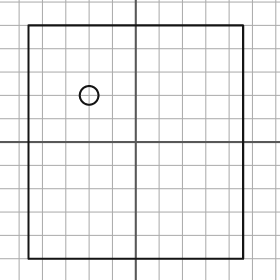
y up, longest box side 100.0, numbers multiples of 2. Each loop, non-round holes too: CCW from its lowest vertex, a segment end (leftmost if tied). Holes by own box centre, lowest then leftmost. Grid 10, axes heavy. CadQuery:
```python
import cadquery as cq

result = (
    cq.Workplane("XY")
    .moveTo(-46.0, -50.0)
    .lineTo(46.0, -50.0)
    .lineTo(46.0, 50.0)
    .lineTo(-46.0, 50.0)
    .close()
    .moveTo(-20.0, 20.0)
    .circle(4.0)
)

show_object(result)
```